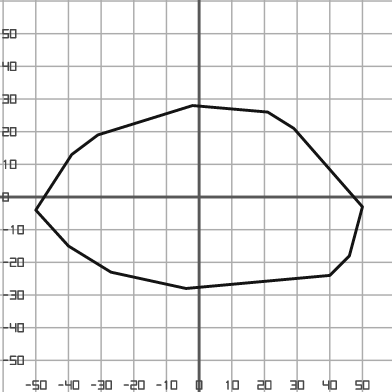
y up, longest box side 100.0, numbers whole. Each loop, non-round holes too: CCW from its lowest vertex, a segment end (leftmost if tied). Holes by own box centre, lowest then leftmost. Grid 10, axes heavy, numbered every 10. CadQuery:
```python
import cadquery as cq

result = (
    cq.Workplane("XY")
    .moveTo(-4.0, -28.0)
    .lineTo(40.0, -24.0)
    .lineTo(46.0, -18.0)
    .lineTo(50.0, -3.0)
    .lineTo(29.0, 21.0)
    .lineTo(21.0, 26.0)
    .lineTo(-2.0, 28.0)
    .lineTo(-31.0, 19.0)
    .lineTo(-39.0, 13.0)
    .lineTo(-50.0, -4.0)
    .lineTo(-40.0, -15.0)
    .lineTo(-27.0, -23.0)
    .close()
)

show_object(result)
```